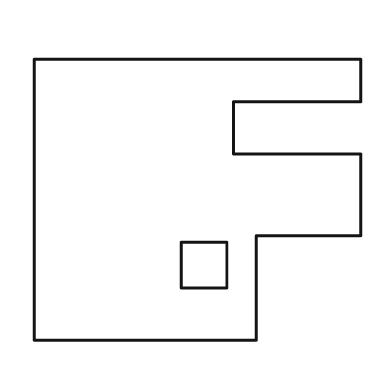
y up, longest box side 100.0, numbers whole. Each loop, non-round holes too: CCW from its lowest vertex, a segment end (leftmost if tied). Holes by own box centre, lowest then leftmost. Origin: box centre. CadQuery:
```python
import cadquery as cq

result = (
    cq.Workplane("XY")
    .moveTo(-50.0, -43.0)
    .lineTo(18.0, -43.0)
    .lineTo(18.0, -11.0)
    .lineTo(50.0, -11.0)
    .lineTo(50.0, 14.0)
    .lineTo(11.0, 14.0)
    .lineTo(11.0, 30.0)
    .lineTo(50.0, 30.0)
    .lineTo(50.0, 43.0)
    .lineTo(-50.0, 43.0)
    .close()
    .moveTo(-5.0, -27.0)
    .lineTo(9.0, -27.0)
    .lineTo(9.0, -13.0)
    .lineTo(-5.0, -13.0)
    .close()
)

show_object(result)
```